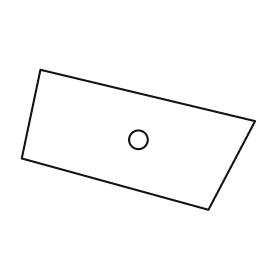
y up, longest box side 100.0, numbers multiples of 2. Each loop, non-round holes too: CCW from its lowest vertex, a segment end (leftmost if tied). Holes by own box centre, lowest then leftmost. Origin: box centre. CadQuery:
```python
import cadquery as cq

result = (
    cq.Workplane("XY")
    .moveTo(30.0, -30.0)
    .lineTo(50.0, 8.0)
    .lineTo(-42.0, 30.0)
    .lineTo(-50.0, -8.0)
    .close()
    .moveTo(0.0, 0.0)
    .circle(4.0)
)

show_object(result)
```